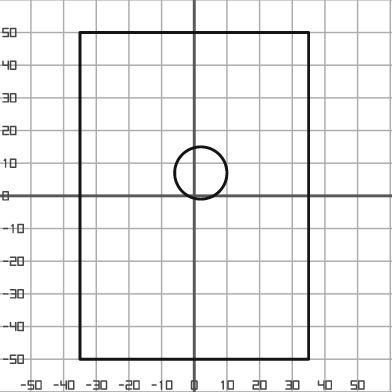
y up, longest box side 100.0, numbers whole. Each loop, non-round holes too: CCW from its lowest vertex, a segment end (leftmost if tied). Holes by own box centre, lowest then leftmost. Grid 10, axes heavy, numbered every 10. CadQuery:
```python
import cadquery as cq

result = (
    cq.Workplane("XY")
    .moveTo(-35.0, -50.0)
    .lineTo(35.0, -50.0)
    .lineTo(35.0, 50.0)
    .lineTo(-35.0, 50.0)
    .close()
    .moveTo(2.0, 7.0)
    .circle(8.0)
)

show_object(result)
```